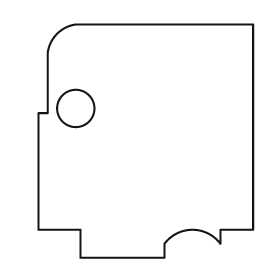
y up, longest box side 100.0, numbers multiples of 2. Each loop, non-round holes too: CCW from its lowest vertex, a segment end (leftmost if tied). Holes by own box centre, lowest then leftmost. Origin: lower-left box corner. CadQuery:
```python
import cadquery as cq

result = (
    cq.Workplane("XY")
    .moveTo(18.0, 0.0)
    .lineTo(54.0, 0.0)
    .lineTo(54.0, 6.0)
    .threePointArc((66.0, 12.0), (78.0, 6.0))
    .lineTo(78.0, 12.0)
    .lineTo(92.0, 12.0)
    .lineTo(92.0, 100.0)
    .lineTo(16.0, 100.0)
    .threePointArc((8.0, 96.0), (4.0, 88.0))
    .lineTo(4.0, 62.0)
    .lineTo(0.0, 62.0)
    .lineTo(0.0, 12.0)
    .lineTo(18.0, 12.0)
    .close()
    .moveTo(16.0, 64.0)
    .circle(8.0)
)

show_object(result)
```